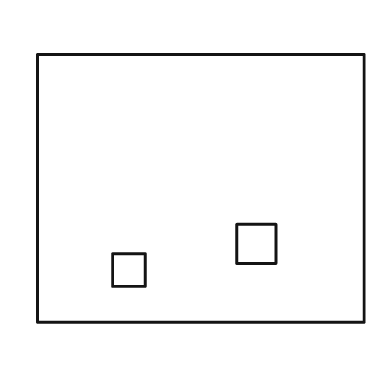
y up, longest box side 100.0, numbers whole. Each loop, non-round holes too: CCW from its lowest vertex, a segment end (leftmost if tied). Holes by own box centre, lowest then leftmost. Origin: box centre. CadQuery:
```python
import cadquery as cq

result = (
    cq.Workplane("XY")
    .moveTo(-50.0, -41.0)
    .lineTo(50.0, -41.0)
    .lineTo(50.0, 41.0)
    .lineTo(-50.0, 41.0)
    .close()
    .moveTo(-27.0, -30.0)
    .lineTo(-17.0, -30.0)
    .lineTo(-17.0, -20.0)
    .lineTo(-27.0, -20.0)
    .close()
    .moveTo(11.0, -23.0)
    .lineTo(23.0, -23.0)
    .lineTo(23.0, -11.0)
    .lineTo(11.0, -11.0)
    .close()
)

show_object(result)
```